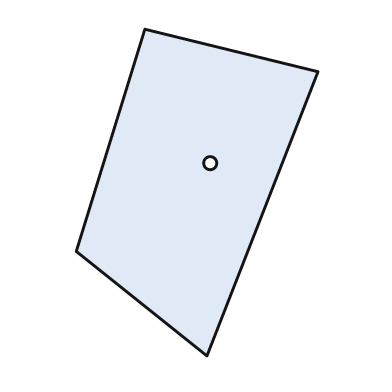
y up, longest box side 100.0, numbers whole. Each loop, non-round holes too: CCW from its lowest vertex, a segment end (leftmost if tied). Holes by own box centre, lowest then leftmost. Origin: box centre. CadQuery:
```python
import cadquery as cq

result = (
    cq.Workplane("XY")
    .moveTo(3.0, -50.0)
    .lineTo(37.0, 37.0)
    .lineTo(-16.0, 50.0)
    .lineTo(-37.0, -18.0)
    .close()
    .moveTo(4.0, 9.0)
    .circle(2.0)
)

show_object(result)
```